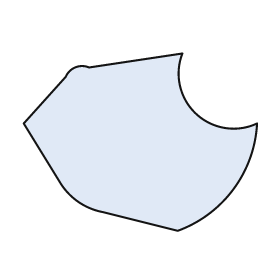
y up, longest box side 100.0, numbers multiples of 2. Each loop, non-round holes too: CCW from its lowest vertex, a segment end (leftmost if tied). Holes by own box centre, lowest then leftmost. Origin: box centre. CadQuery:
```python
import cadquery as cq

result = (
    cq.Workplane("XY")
    .moveTo(16.0, -38.0)
    .threePointArc((40.0, -20.0), (50.0, 8.0))
    .threePointArc((24.0, 12.0), (18.0, 38.0))
    .lineTo(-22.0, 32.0)
    .threePointArc((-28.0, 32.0), (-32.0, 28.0))
    .lineTo(-50.0, 8.0)
    .lineTo(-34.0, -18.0)
    .threePointArc((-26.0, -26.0), (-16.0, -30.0))
    .close()
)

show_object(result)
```